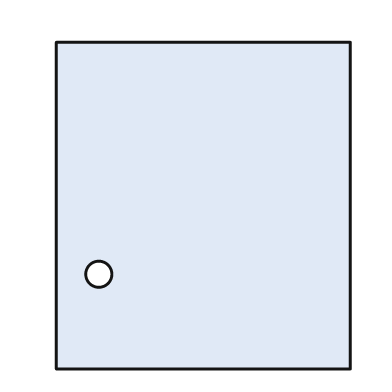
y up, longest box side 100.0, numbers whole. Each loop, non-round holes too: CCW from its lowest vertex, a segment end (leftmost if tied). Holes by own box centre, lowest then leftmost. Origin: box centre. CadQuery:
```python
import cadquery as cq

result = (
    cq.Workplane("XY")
    .moveTo(-45.0, -50.0)
    .lineTo(45.0, -50.0)
    .lineTo(45.0, 50.0)
    .lineTo(-45.0, 50.0)
    .close()
    .moveTo(-32.0, -21.0)
    .circle(4.0)
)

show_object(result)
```